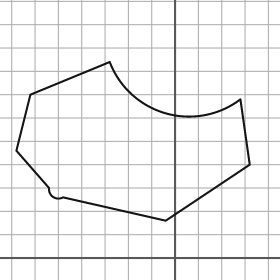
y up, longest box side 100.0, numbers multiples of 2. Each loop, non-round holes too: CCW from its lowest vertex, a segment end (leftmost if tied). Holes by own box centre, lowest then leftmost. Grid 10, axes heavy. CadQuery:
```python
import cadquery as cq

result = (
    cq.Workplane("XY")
    .moveTo(-4.0, 16.0)
    .lineTo(32.0, 40.0)
    .lineTo(28.0, 68.0)
    .threePointArc((-4.0, 62.0), (-28.0, 84.0))
    .lineTo(-62.0, 70.0)
    .lineTo(-68.0, 46.0)
    .lineTo(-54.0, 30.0)
    .threePointArc((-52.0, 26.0), (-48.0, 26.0))
    .close()
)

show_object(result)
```